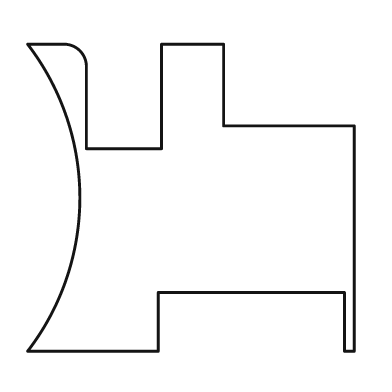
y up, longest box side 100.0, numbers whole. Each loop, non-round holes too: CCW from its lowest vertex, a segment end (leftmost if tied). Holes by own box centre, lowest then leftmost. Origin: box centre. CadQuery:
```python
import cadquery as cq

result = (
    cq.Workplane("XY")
    .moveTo(-50.0, -47.0)
    .lineTo(-10.0, -47.0)
    .lineTo(-10.0, -29.0)
    .lineTo(47.0, -29.0)
    .lineTo(47.0, -47.0)
    .lineTo(50.0, -47.0)
    .lineTo(50.0, 22.0)
    .lineTo(10.0, 22.0)
    .lineTo(10.0, 47.0)
    .lineTo(-9.0, 47.0)
    .lineTo(-9.0, 15.0)
    .lineTo(-32.0, 15.0)
    .lineTo(-32.0, 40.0)
    .threePointArc((-34.0, 45.0), (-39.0, 47.0))
    .lineTo(-50.0, 47.0)
    .threePointArc((-34.0, 0.0), (-50.0, -47.0))
    .close()
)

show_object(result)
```